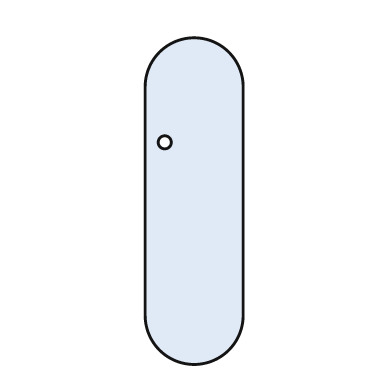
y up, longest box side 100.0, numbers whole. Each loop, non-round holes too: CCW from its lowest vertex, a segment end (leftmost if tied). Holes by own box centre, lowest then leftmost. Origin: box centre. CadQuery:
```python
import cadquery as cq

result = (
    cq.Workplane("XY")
    .moveTo(-15.0, -35.0)
    .threePointArc((0.0, -50.0), (15.0, -35.0))
    .lineTo(15.0, 35.0)
    .threePointArc((0.0, 50.0), (-15.0, 35.0))
    .close()
    .moveTo(-9.0, 18.0)
    .circle(2.0)
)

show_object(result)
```